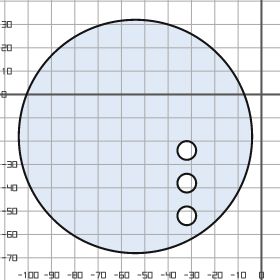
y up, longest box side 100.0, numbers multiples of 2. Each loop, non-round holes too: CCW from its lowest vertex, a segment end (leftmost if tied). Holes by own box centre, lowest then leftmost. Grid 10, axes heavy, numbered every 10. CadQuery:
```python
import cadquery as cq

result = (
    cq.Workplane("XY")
    .moveTo(-54.0, -18.0)
    .circle(50.0)
    .moveTo(-32.0, -52.0)
    .circle(4.0)
    .moveTo(-32.0, -38.0)
    .circle(4.0)
    .moveTo(-32.0, -24.0)
    .circle(4.0)
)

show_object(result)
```